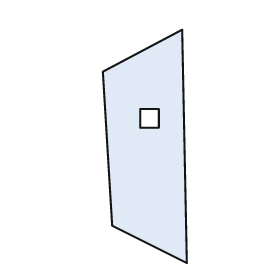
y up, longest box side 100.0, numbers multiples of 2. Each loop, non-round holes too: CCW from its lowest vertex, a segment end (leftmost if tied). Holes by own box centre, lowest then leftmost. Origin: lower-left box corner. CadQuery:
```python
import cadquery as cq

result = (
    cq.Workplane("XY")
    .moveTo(36.0, 0.0)
    .lineTo(34.0, 100.0)
    .lineTo(0.0, 82.0)
    .lineTo(4.0, 16.0)
    .close()
    .moveTo(16.0, 58.0)
    .lineTo(24.0, 58.0)
    .lineTo(24.0, 66.0)
    .lineTo(16.0, 66.0)
    .close()
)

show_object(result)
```